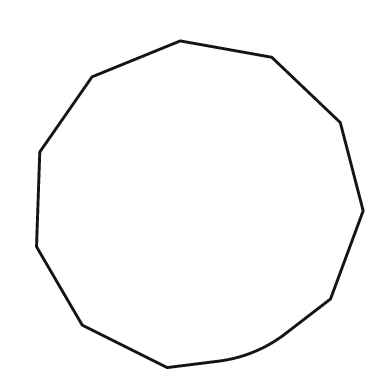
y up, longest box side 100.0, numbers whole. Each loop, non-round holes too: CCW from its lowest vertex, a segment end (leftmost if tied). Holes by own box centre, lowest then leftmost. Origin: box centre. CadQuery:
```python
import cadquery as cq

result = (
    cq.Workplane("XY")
    .moveTo(-10.0, -50.0)
    .lineTo(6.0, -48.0)
    .threePointArc((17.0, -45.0), (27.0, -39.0))
    .lineTo(40.0, -29.0)
    .lineTo(50.0, -2.0)
    .lineTo(43.0, 25.0)
    .lineTo(22.0, 45.0)
    .lineTo(-6.0, 50.0)
    .lineTo(-33.0, 39.0)
    .lineTo(-49.0, 16.0)
    .lineTo(-50.0, -13.0)
    .lineTo(-36.0, -37.0)
    .close()
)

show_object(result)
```